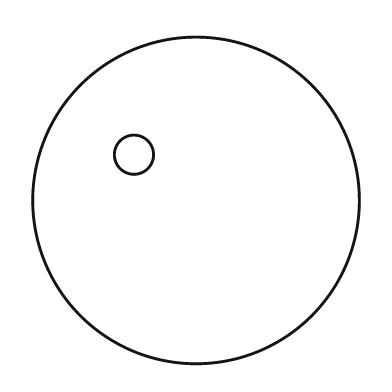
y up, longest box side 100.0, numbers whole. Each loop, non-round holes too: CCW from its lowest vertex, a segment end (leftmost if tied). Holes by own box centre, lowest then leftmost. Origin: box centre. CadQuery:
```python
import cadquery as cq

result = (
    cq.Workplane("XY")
    .moveTo(0.0, 0.0)
    .circle(50.0)
    .moveTo(-19.0, 14.0)
    .circle(6.0)
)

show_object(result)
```